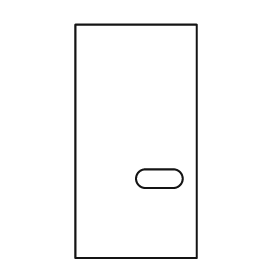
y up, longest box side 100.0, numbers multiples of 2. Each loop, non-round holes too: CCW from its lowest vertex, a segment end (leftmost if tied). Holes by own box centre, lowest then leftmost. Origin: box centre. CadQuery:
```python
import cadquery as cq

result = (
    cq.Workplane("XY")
    .moveTo(-26.0, -50.0)
    .lineTo(26.0, -50.0)
    .lineTo(26.0, 50.0)
    .lineTo(-26.0, 50.0)
    .close()
    .moveTo(4.0, -20.0)
    .lineTo(16.0, -20.0)
    .threePointArc((20.0, -16.0), (16.0, -12.0))
    .lineTo(4.0, -12.0)
    .threePointArc((0.0, -16.0), (4.0, -20.0))
    .close()
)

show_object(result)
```